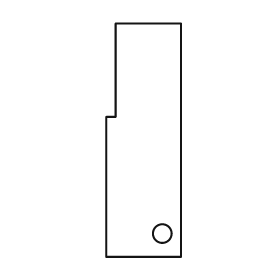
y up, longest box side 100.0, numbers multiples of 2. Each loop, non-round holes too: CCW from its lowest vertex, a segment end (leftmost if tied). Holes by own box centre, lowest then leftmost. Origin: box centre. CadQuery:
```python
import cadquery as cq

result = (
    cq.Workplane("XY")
    .moveTo(-16.0, -50.0)
    .lineTo(16.0, -50.0)
    .lineTo(16.0, 50.0)
    .lineTo(-12.0, 50.0)
    .lineTo(-12.0, 10.0)
    .lineTo(-16.0, 10.0)
    .close()
    .moveTo(8.0, -40.0)
    .circle(4.0)
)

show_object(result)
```